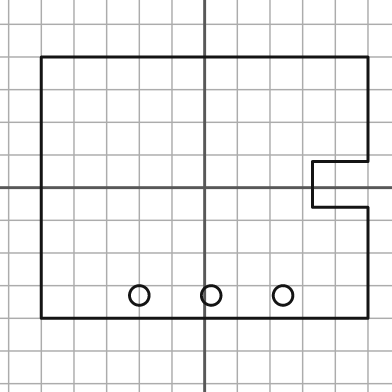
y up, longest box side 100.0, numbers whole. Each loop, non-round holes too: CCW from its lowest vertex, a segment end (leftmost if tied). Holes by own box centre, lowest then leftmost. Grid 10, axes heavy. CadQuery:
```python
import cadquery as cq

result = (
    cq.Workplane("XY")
    .moveTo(-50.0, -40.0)
    .lineTo(50.0, -40.0)
    .lineTo(50.0, -6.0)
    .lineTo(33.0, -6.0)
    .lineTo(33.0, 8.0)
    .lineTo(50.0, 8.0)
    .lineTo(50.0, 40.0)
    .lineTo(-50.0, 40.0)
    .close()
    .moveTo(-20.0, -33.0)
    .circle(3.0)
    .moveTo(2.0, -33.0)
    .circle(3.0)
    .moveTo(24.0, -33.0)
    .circle(3.0)
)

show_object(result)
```